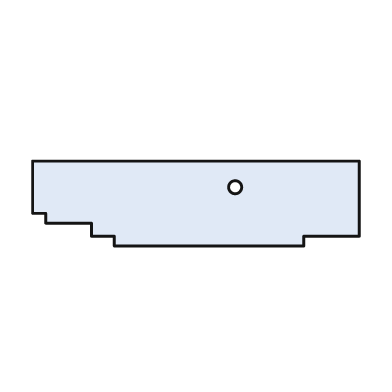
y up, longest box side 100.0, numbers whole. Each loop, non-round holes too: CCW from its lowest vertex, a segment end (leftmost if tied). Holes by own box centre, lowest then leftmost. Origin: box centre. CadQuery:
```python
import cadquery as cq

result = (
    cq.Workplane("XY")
    .moveTo(-25.0, -13.0)
    .lineTo(33.0, -13.0)
    .lineTo(33.0, -10.0)
    .lineTo(50.0, -10.0)
    .lineTo(50.0, 13.0)
    .lineTo(-50.0, 13.0)
    .lineTo(-50.0, -3.0)
    .lineTo(-46.0, -3.0)
    .lineTo(-46.0, -6.0)
    .lineTo(-32.0, -6.0)
    .lineTo(-32.0, -10.0)
    .lineTo(-25.0, -10.0)
    .close()
    .moveTo(12.0, 5.0)
    .circle(2.0)
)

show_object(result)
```